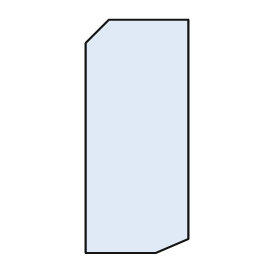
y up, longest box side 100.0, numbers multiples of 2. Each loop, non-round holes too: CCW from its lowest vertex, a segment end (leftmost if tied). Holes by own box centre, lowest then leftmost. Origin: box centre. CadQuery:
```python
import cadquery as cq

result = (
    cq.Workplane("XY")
    .moveTo(-22.0, -50.0)
    .lineTo(8.0, -50.0)
    .lineTo(22.0, -44.0)
    .lineTo(22.0, 50.0)
    .lineTo(-12.0, 50.0)
    .lineTo(-22.0, 40.0)
    .close()
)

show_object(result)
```